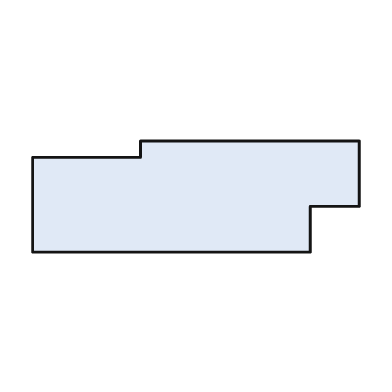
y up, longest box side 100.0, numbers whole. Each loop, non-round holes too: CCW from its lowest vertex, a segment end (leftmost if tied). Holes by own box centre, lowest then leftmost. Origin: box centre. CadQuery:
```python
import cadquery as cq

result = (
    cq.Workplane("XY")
    .moveTo(-50.0, -17.0)
    .lineTo(35.0, -17.0)
    .lineTo(35.0, -3.0)
    .lineTo(50.0, -3.0)
    .lineTo(50.0, 17.0)
    .lineTo(-17.0, 17.0)
    .lineTo(-17.0, 12.0)
    .lineTo(-50.0, 12.0)
    .close()
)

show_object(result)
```